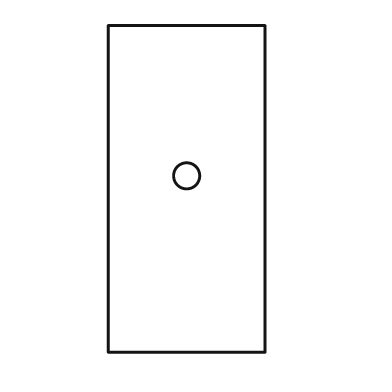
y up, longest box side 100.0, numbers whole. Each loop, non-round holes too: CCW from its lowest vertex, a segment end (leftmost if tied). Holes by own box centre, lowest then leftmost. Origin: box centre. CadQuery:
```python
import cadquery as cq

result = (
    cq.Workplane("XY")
    .moveTo(-24.0, -50.0)
    .lineTo(24.0, -50.0)
    .lineTo(24.0, 50.0)
    .lineTo(-24.0, 50.0)
    .close()
    .moveTo(0.0, 4.0)
    .circle(4.0)
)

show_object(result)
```